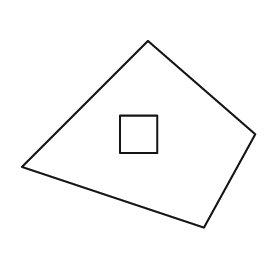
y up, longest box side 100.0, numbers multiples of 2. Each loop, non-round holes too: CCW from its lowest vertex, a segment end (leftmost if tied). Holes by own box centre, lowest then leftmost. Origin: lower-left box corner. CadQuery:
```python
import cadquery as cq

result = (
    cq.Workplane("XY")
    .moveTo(78.0, 0.0)
    .lineTo(100.0, 40.0)
    .lineTo(54.0, 80.0)
    .lineTo(0.0, 26.0)
    .close()
    .moveTo(42.0, 32.0)
    .lineTo(58.0, 32.0)
    .lineTo(58.0, 48.0)
    .lineTo(42.0, 48.0)
    .close()
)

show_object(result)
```